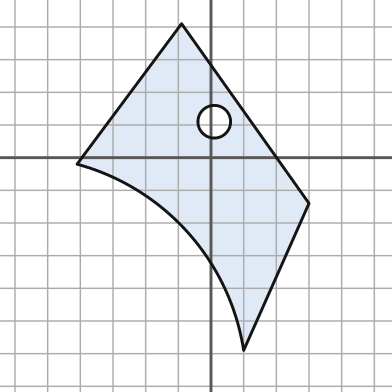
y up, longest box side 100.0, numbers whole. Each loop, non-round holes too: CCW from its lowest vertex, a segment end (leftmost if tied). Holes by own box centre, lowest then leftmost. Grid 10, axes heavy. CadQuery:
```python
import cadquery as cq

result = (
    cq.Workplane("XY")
    .moveTo(10.0, -59.0)
    .lineTo(30.0, -14.0)
    .lineTo(-9.0, 41.0)
    .lineTo(-41.0, -2.0)
    .threePointArc((-7.0, -23.0), (10.0, -59.0))
    .close()
    .moveTo(1.0, 11.0)
    .circle(5.0)
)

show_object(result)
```